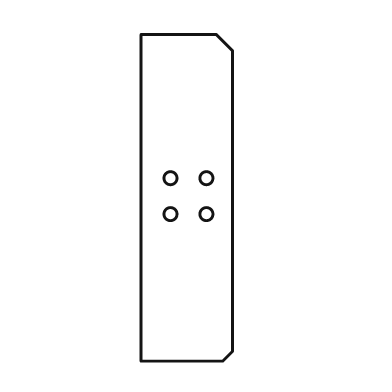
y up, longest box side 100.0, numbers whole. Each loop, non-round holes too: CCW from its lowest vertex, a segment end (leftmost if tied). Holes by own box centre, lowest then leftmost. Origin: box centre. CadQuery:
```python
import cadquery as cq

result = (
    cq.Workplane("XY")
    .moveTo(-14.0, -50.0)
    .lineTo(11.0, -50.0)
    .lineTo(14.0, -47.0)
    .lineTo(14.0, 45.0)
    .lineTo(9.0, 50.0)
    .lineTo(-14.0, 50.0)
    .close()
    .moveTo(-5.0, -5.0)
    .circle(2.0)
    .moveTo(6.0, -5.0)
    .circle(2.0)
    .moveTo(-5.0, 6.0)
    .circle(2.0)
    .moveTo(6.0, 6.0)
    .circle(2.0)
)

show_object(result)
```